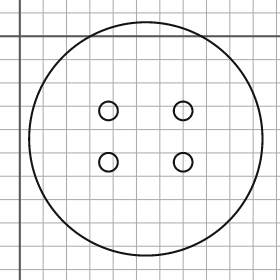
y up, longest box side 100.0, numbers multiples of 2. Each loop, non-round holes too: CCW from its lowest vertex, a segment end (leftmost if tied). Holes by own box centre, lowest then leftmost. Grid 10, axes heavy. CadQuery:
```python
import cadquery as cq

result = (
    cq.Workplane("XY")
    .moveTo(54.0, -44.0)
    .circle(50.0)
    .moveTo(38.0, -54.0)
    .circle(4.0)
    .moveTo(70.0, -54.0)
    .circle(4.0)
    .moveTo(38.0, -32.0)
    .circle(4.0)
    .moveTo(70.0, -32.0)
    .circle(4.0)
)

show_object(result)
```